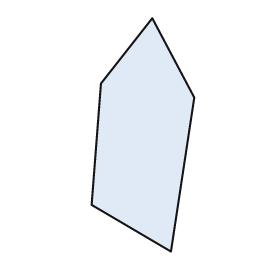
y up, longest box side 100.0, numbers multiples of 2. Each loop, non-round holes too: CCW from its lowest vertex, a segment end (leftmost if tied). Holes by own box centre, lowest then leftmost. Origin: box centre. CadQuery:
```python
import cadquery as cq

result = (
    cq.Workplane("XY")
    .moveTo(12.0, -50.0)
    .lineTo(22.0, 16.0)
    .lineTo(4.0, 50.0)
    .lineTo(-18.0, 22.0)
    .lineTo(-22.0, -30.0)
    .close()
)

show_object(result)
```